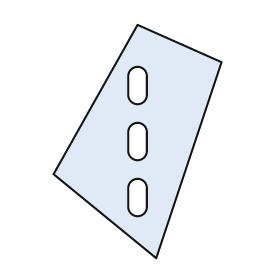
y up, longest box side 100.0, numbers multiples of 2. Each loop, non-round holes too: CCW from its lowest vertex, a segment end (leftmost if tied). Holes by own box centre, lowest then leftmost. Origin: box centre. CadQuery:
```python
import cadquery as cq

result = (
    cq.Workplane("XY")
    .moveTo(8.0, -50.0)
    .lineTo(36.0, 34.0)
    .lineTo(0.0, 50.0)
    .lineTo(-36.0, -14.0)
    .close()
    .moveTo(-4.0, -28.0)
    .threePointArc((0.0, -32.0), (4.0, -28.0))
    .lineTo(4.0, -20.0)
    .threePointArc((0.0, -16.0), (-4.0, -20.0))
    .close()
    .moveTo(-4.0, -4.0)
    .threePointArc((0.0, -8.0), (4.0, -4.0))
    .lineTo(4.0, 4.0)
    .threePointArc((0.0, 8.0), (-4.0, 4.0))
    .close()
    .moveTo(-4.0, 20.0)
    .threePointArc((0.0, 16.0), (4.0, 20.0))
    .lineTo(4.0, 28.0)
    .threePointArc((0.0, 32.0), (-4.0, 28.0))
    .close()
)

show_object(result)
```